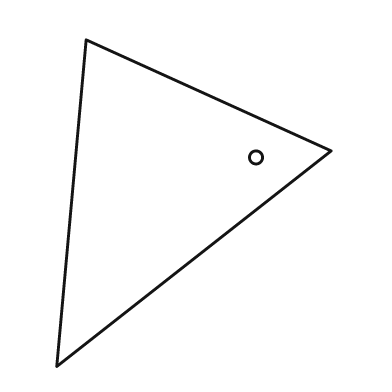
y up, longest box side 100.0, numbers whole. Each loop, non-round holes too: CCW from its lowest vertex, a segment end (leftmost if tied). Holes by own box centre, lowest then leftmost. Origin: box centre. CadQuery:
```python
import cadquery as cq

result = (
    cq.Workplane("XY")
    .moveTo(-42.0, -50.0)
    .lineTo(42.0, 16.0)
    .lineTo(-33.0, 50.0)
    .close()
    .moveTo(19.0, 14.0)
    .circle(2.0)
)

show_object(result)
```